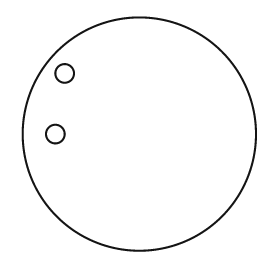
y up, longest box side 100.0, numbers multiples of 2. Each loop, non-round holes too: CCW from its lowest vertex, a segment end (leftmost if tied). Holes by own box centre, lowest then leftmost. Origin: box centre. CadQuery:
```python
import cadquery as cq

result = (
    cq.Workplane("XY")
    .moveTo(0.0, 0.0)
    .circle(50.0)
    .moveTo(-36.0, 0.0)
    .circle(4.0)
    .moveTo(-32.0, 26.0)
    .circle(4.0)
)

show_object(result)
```